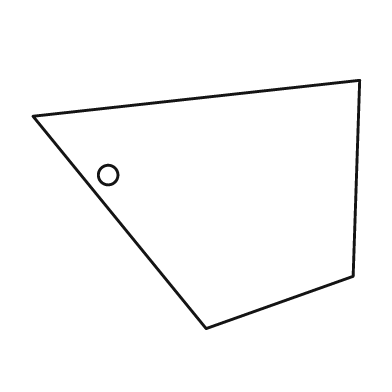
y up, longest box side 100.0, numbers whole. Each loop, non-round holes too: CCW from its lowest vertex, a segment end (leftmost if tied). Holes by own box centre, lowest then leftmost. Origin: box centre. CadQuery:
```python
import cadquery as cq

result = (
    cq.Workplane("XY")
    .moveTo(3.0, -38.0)
    .lineTo(48.0, -22.0)
    .lineTo(50.0, 38.0)
    .lineTo(-50.0, 27.0)
    .close()
    .moveTo(-27.0, 9.0)
    .circle(3.0)
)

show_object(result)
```